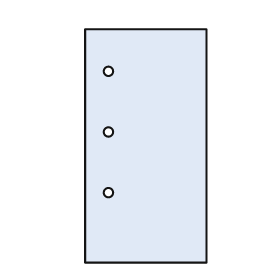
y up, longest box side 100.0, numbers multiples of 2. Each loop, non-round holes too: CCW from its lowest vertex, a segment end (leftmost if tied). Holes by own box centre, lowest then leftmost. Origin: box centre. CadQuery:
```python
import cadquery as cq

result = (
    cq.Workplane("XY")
    .moveTo(-26.0, -50.0)
    .lineTo(26.0, -50.0)
    .lineTo(26.0, 50.0)
    .lineTo(-26.0, 50.0)
    .close()
    .moveTo(-16.0, -20.0)
    .circle(2.0)
    .moveTo(-16.0, 6.0)
    .circle(2.0)
    .moveTo(-16.0, 32.0)
    .circle(2.0)
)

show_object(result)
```